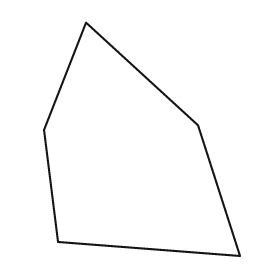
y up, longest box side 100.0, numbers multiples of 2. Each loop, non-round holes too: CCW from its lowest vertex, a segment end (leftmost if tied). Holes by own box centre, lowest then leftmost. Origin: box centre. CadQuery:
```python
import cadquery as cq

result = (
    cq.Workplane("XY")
    .moveTo(42.0, -50.0)
    .lineTo(24.0, 6.0)
    .lineTo(-24.0, 50.0)
    .lineTo(-42.0, 4.0)
    .lineTo(-36.0, -44.0)
    .close()
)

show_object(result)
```